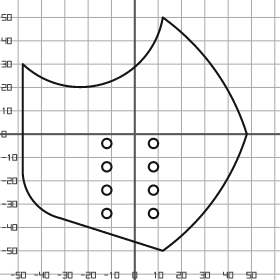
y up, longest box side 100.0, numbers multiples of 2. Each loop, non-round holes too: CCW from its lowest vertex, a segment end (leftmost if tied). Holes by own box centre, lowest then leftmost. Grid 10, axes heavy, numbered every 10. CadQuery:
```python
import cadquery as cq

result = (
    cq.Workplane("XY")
    .moveTo(12.0, -50.0)
    .threePointArc((34.0, -28.0), (48.0, 0.0))
    .threePointArc((34.0, 28.0), (12.0, 50.0))
    .threePointArc((-12.0, 22.0), (-48.0, 30.0))
    .lineTo(-48.0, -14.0)
    .threePointArc((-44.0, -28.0), (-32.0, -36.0))
    .close()
    .moveTo(-12.0, -34.0)
    .circle(2.0)
    .moveTo(8.0, -34.0)
    .circle(2.0)
    .moveTo(-12.0, -24.0)
    .circle(2.0)
    .moveTo(8.0, -24.0)
    .circle(2.0)
    .moveTo(-12.0, -14.0)
    .circle(2.0)
    .moveTo(8.0, -14.0)
    .circle(2.0)
    .moveTo(-12.0, -4.0)
    .circle(2.0)
    .moveTo(8.0, -4.0)
    .circle(2.0)
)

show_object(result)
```